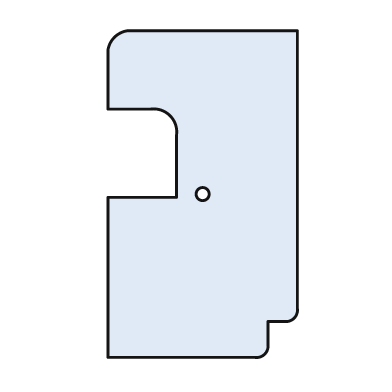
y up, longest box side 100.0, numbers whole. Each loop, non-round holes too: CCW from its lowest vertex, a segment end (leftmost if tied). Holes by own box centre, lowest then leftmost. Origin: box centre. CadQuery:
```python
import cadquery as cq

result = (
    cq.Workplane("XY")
    .moveTo(-29.0, -50.0)
    .lineTo(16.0, -50.0)
    .threePointArc((19.0, -49.0), (20.0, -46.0))
    .lineTo(20.0, -39.0)
    .lineTo(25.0, -39.0)
    .threePointArc((28.0, -38.0), (29.0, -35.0))
    .lineTo(29.0, 50.0)
    .lineTo(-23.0, 50.0)
    .threePointArc((-27.0, 48.0), (-29.0, 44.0))
    .lineTo(-29.0, 26.0)
    .lineTo(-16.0, 26.0)
    .threePointArc((-10.0, 24.0), (-8.0, 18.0))
    .lineTo(-8.0, -1.0)
    .lineTo(-29.0, -1.0)
    .close()
    .moveTo(0.0, 0.0)
    .circle(2.0)
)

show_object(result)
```